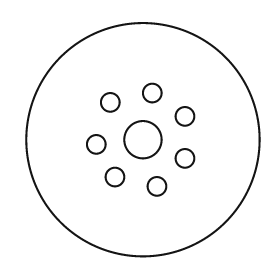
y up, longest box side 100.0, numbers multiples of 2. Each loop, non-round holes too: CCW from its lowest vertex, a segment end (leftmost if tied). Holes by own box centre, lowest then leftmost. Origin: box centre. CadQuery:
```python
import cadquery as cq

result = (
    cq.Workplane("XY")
    .moveTo(0.0, 0.0)
    .circle(50.0)
    .moveTo(6.0, -20.0)
    .circle(4.0)
    .moveTo(-12.0, -16.0)
    .circle(4.0)
    .moveTo(18.0, -8.0)
    .circle(4.0)
    .moveTo(-20.0, -2.0)
    .circle(4.0)
    .moveTo(0.0, 0.0)
    .circle(8.0)
    .moveTo(18.0, 10.0)
    .circle(4.0)
    .moveTo(-14.0, 16.0)
    .circle(4.0)
    .moveTo(4.0, 20.0)
    .circle(4.0)
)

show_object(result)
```